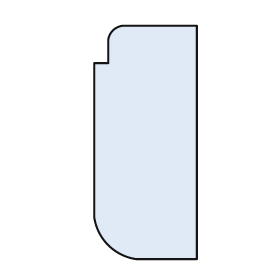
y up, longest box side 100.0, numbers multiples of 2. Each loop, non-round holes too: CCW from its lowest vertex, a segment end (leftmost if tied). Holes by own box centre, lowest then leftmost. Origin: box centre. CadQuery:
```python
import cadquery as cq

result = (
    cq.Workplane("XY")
    .moveTo(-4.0, -50.0)
    .lineTo(22.0, -50.0)
    .lineTo(22.0, 50.0)
    .lineTo(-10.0, 50.0)
    .threePointArc((-14.0, 48.0), (-16.0, 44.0))
    .lineTo(-16.0, 34.0)
    .lineTo(-22.0, 34.0)
    .lineTo(-22.0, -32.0)
    .threePointArc((-16.0, -44.0), (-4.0, -50.0))
    .close()
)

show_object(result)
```